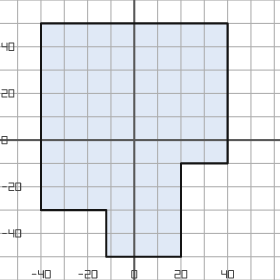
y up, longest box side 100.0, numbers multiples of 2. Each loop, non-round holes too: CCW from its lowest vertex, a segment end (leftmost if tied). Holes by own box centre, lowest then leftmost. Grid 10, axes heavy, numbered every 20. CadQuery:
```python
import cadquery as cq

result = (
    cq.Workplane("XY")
    .moveTo(-12.0, -50.0)
    .lineTo(20.0, -50.0)
    .lineTo(20.0, -10.0)
    .lineTo(40.0, -10.0)
    .lineTo(40.0, 50.0)
    .lineTo(-40.0, 50.0)
    .lineTo(-40.0, -30.0)
    .lineTo(-12.0, -30.0)
    .close()
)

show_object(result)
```